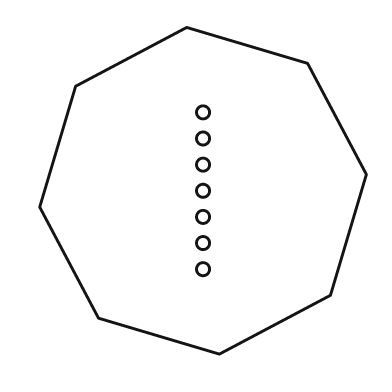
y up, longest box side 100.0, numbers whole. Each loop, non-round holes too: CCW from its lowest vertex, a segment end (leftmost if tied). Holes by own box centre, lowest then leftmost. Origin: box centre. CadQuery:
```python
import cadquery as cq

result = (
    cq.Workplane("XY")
    .moveTo(5.0, -50.0)
    .lineTo(39.0, -32.0)
    .lineTo(50.0, 5.0)
    .lineTo(32.0, 39.0)
    .lineTo(-5.0, 50.0)
    .lineTo(-39.0, 32.0)
    .lineTo(-50.0, -5.0)
    .lineTo(-32.0, -39.0)
    .close()
    .moveTo(0.0, -24.0)
    .circle(2.0)
    .moveTo(0.0, -16.0)
    .circle(2.0)
    .moveTo(0.0, -8.0)
    .circle(2.0)
    .moveTo(0.0, 0.0)
    .circle(2.0)
    .moveTo(0.0, 8.0)
    .circle(2.0)
    .moveTo(0.0, 16.0)
    .circle(2.0)
    .moveTo(0.0, 24.0)
    .circle(2.0)
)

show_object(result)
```